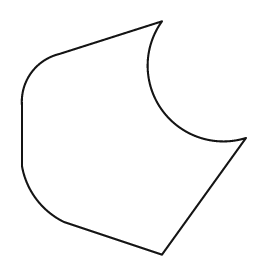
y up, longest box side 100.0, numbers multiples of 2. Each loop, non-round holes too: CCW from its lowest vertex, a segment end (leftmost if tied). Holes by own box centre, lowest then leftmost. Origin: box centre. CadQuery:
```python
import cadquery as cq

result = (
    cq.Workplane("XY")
    .moveTo(12.0, -50.0)
    .lineTo(48.0, 0.0)
    .threePointArc((12.0, 12.0), (12.0, 50.0))
    .lineTo(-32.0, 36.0)
    .threePointArc((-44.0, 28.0), (-48.0, 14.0))
    .lineTo(-48.0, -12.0)
    .threePointArc((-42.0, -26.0), (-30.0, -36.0))
    .close()
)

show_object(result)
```